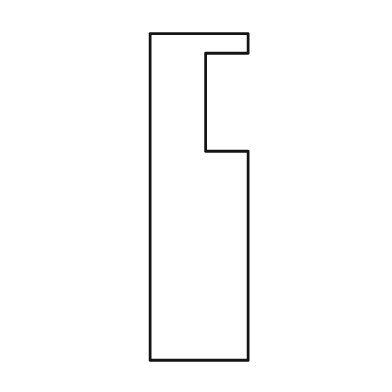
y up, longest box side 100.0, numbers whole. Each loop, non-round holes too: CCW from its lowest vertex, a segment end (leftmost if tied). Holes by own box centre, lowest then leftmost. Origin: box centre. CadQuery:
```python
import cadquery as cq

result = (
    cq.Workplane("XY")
    .moveTo(-15.0, -50.0)
    .lineTo(15.0, -50.0)
    .lineTo(15.0, 14.0)
    .lineTo(2.0, 14.0)
    .lineTo(2.0, 44.0)
    .lineTo(15.0, 44.0)
    .lineTo(15.0, 50.0)
    .lineTo(-15.0, 50.0)
    .close()
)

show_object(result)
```